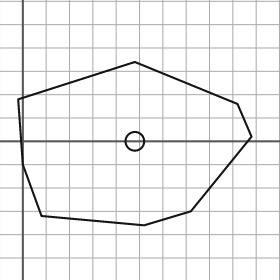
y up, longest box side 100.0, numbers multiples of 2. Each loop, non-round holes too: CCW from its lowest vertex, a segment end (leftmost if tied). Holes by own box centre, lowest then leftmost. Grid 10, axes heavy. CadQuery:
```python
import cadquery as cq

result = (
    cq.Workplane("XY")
    .moveTo(52.0, -36.0)
    .lineTo(72.0, -30.0)
    .lineTo(98.0, 2.0)
    .lineTo(92.0, 16.0)
    .lineTo(48.0, 34.0)
    .lineTo(-2.0, 18.0)
    .lineTo(0.0, -10.0)
    .lineTo(8.0, -32.0)
    .close()
    .moveTo(48.0, 0.0)
    .circle(4.0)
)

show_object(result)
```